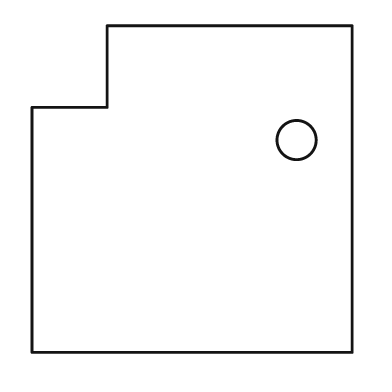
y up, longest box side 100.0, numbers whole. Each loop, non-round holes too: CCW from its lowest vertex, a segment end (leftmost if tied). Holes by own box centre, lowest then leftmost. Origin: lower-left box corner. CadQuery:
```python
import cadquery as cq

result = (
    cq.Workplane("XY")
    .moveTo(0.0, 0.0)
    .lineTo(98.0, 0.0)
    .lineTo(98.0, 100.0)
    .lineTo(23.0, 100.0)
    .lineTo(23.0, 75.0)
    .lineTo(0.0, 75.0)
    .close()
    .moveTo(81.0, 65.0)
    .circle(6.0)
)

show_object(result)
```